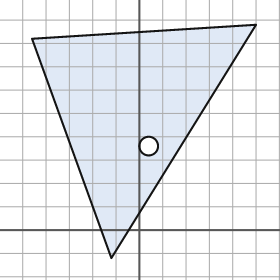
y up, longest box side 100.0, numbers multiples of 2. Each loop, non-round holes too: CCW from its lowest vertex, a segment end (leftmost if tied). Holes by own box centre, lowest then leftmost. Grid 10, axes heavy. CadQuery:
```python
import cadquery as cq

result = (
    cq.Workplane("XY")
    .moveTo(-12.0, -12.0)
    .lineTo(50.0, 88.0)
    .lineTo(-46.0, 82.0)
    .close()
    .moveTo(4.0, 36.0)
    .circle(4.0)
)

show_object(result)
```